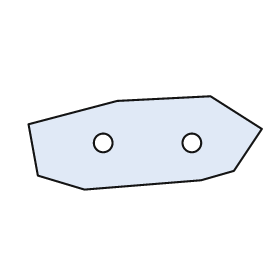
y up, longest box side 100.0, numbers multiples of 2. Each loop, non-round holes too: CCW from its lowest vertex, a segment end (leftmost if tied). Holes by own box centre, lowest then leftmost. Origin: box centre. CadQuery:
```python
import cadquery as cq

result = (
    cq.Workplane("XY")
    .moveTo(-26.0, -20.0)
    .lineTo(24.0, -16.0)
    .lineTo(38.0, -12.0)
    .lineTo(50.0, 6.0)
    .lineTo(28.0, 20.0)
    .lineTo(-12.0, 18.0)
    .lineTo(-50.0, 8.0)
    .lineTo(-46.0, -14.0)
    .close()
    .moveTo(-18.0, 0.0)
    .circle(4.0)
    .moveTo(20.0, 0.0)
    .circle(4.0)
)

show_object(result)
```